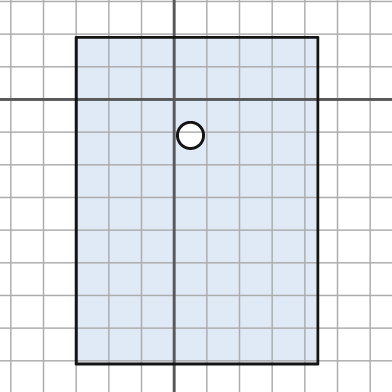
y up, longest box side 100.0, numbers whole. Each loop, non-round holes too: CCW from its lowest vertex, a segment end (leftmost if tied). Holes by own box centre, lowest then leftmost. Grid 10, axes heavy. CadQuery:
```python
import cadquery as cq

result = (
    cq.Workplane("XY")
    .moveTo(-30.0, -81.0)
    .lineTo(44.0, -81.0)
    .lineTo(44.0, 19.0)
    .lineTo(-30.0, 19.0)
    .close()
    .moveTo(5.0, -11.0)
    .circle(4.0)
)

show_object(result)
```